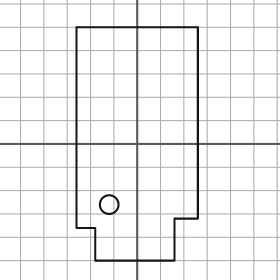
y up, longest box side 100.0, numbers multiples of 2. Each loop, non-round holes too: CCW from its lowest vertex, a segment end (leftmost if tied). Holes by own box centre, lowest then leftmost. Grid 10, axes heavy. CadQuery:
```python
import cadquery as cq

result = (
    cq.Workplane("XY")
    .moveTo(-18.0, -50.0)
    .lineTo(16.0, -50.0)
    .lineTo(16.0, -32.0)
    .lineTo(26.0, -32.0)
    .lineTo(26.0, 50.0)
    .lineTo(-26.0, 50.0)
    .lineTo(-26.0, -36.0)
    .lineTo(-18.0, -36.0)
    .close()
    .moveTo(-12.0, -26.0)
    .circle(4.0)
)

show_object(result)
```